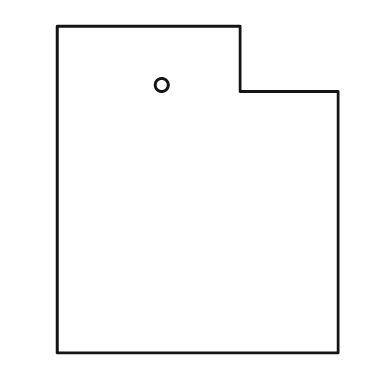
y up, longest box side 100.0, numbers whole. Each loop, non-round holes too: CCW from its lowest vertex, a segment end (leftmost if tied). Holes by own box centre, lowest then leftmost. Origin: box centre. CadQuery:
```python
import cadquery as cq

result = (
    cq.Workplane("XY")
    .moveTo(-43.0, -50.0)
    .lineTo(43.0, -50.0)
    .lineTo(43.0, 30.0)
    .lineTo(13.0, 30.0)
    .lineTo(13.0, 50.0)
    .lineTo(-43.0, 50.0)
    .close()
    .moveTo(-11.0, 32.0)
    .circle(2.0)
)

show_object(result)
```